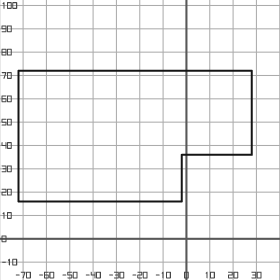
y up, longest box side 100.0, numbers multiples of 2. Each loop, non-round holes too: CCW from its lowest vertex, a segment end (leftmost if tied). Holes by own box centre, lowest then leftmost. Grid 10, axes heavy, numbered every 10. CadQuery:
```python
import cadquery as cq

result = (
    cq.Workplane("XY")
    .moveTo(-72.0, 16.0)
    .lineTo(-2.0, 16.0)
    .lineTo(-2.0, 36.0)
    .lineTo(28.0, 36.0)
    .lineTo(28.0, 72.0)
    .lineTo(-72.0, 72.0)
    .close()
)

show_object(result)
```